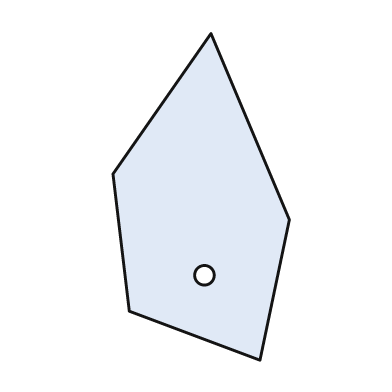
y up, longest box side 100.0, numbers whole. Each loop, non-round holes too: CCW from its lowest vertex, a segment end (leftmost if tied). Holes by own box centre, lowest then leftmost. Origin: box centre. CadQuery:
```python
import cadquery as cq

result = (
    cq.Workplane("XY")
    .moveTo(18.0, -50.0)
    .lineTo(27.0, -7.0)
    .lineTo(3.0, 50.0)
    .lineTo(-27.0, 7.0)
    .lineTo(-22.0, -35.0)
    .close()
    .moveTo(1.0, -24.0)
    .circle(3.0)
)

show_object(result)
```